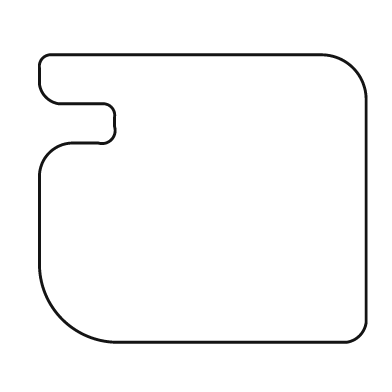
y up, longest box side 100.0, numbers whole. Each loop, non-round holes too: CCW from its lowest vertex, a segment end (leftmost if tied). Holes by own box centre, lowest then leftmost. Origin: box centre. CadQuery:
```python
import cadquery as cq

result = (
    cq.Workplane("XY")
    .moveTo(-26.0, -44.0)
    .lineTo(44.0, -44.0)
    .threePointArc((48.0, -42.0), (50.0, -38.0))
    .lineTo(50.0, 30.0)
    .threePointArc((46.0, 40.0), (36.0, 44.0))
    .lineTo(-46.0, 44.0)
    .threePointArc((-49.0, 43.0), (-50.0, 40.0))
    .lineTo(-50.0, 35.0)
    .threePointArc((-48.0, 31.0), (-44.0, 29.0))
    .lineTo(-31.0, 29.0)
    .threePointArc((-28.0, 28.0), (-27.0, 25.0))
    .lineTo(-27.0, 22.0)
    .threePointArc((-28.0, 18.0), (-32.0, 17.0))
    .lineTo(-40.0, 17.0)
    .threePointArc((-47.0, 14.0), (-50.0, 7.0))
    .lineTo(-50.0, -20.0)
    .threePointArc((-43.0, -37.0), (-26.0, -44.0))
    .close()
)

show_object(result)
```